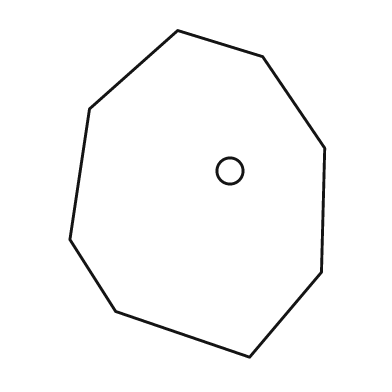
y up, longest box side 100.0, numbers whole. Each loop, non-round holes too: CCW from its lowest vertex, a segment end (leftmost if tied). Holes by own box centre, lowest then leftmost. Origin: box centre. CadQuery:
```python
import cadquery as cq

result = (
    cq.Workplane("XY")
    .moveTo(16.0, -50.0)
    .lineTo(38.0, -24.0)
    .lineTo(39.0, 14.0)
    .lineTo(20.0, 42.0)
    .lineTo(-6.0, 50.0)
    .lineTo(-33.0, 26.0)
    .lineTo(-39.0, -14.0)
    .lineTo(-25.0, -36.0)
    .close()
    .moveTo(10.0, 7.0)
    .circle(4.0)
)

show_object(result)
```